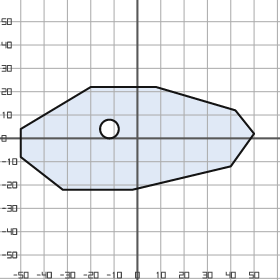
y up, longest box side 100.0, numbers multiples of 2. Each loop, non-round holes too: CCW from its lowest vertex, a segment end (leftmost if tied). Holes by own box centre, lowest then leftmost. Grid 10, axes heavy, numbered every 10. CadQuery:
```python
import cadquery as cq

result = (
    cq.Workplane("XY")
    .moveTo(-32.0, -22.0)
    .lineTo(-2.0, -22.0)
    .lineTo(40.0, -12.0)
    .lineTo(50.0, 2.0)
    .lineTo(42.0, 12.0)
    .lineTo(8.0, 22.0)
    .lineTo(-20.0, 22.0)
    .lineTo(-50.0, 4.0)
    .lineTo(-50.0, -8.0)
    .close()
    .moveTo(-12.0, 4.0)
    .circle(4.0)
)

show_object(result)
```